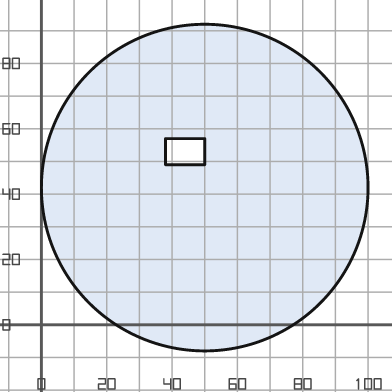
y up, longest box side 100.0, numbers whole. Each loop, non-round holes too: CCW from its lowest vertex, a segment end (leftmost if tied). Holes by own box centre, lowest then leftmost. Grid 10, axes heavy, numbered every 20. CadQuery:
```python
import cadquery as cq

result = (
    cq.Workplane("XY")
    .moveTo(50.0, 42.0)
    .circle(50.0)
    .moveTo(38.0, 49.0)
    .lineTo(50.0, 49.0)
    .lineTo(50.0, 57.0)
    .lineTo(38.0, 57.0)
    .close()
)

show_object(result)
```